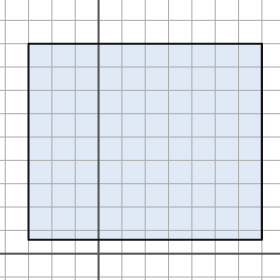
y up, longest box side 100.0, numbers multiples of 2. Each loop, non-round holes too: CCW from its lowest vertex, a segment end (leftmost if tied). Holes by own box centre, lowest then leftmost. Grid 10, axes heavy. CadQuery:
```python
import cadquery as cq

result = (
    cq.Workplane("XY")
    .moveTo(-30.0, 6.0)
    .lineTo(70.0, 6.0)
    .lineTo(70.0, 90.0)
    .lineTo(-30.0, 90.0)
    .close()
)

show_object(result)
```